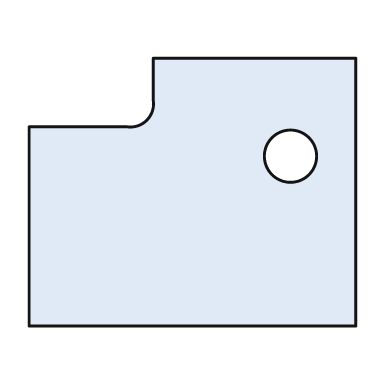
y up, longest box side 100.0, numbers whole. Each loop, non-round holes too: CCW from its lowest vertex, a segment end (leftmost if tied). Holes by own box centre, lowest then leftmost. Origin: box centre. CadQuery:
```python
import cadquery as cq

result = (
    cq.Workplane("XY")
    .moveTo(-50.0, -41.0)
    .lineTo(50.0, -41.0)
    .lineTo(50.0, 41.0)
    .lineTo(-12.0, 41.0)
    .lineTo(-12.0, 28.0)
    .threePointArc((-14.0, 22.0), (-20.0, 20.0))
    .lineTo(-50.0, 20.0)
    .close()
    .moveTo(30.0, 11.0)
    .circle(8.0)
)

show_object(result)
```